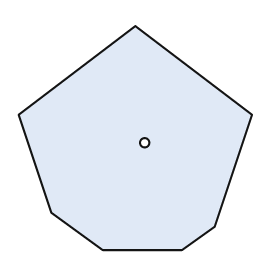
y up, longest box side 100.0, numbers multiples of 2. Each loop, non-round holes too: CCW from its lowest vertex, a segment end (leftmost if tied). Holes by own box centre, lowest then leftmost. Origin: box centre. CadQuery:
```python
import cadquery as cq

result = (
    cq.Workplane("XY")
    .moveTo(-14.0, -48.0)
    .lineTo(20.0, -48.0)
    .lineTo(34.0, -38.0)
    .lineTo(50.0, 10.0)
    .lineTo(0.0, 48.0)
    .lineTo(-50.0, 10.0)
    .lineTo(-36.0, -32.0)
    .close()
    .moveTo(4.0, -2.0)
    .circle(2.0)
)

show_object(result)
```